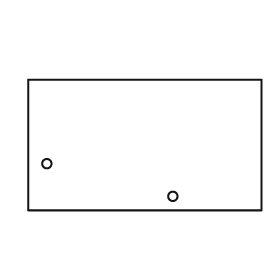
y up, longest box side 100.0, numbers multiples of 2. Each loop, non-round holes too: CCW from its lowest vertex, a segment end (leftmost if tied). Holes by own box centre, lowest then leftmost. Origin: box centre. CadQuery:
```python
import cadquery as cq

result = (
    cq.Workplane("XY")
    .moveTo(-50.0, -28.0)
    .lineTo(50.0, -28.0)
    .lineTo(50.0, 28.0)
    .lineTo(-50.0, 28.0)
    .close()
    .moveTo(12.0, -22.0)
    .circle(2.0)
    .moveTo(-42.0, -8.0)
    .circle(2.0)
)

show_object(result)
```